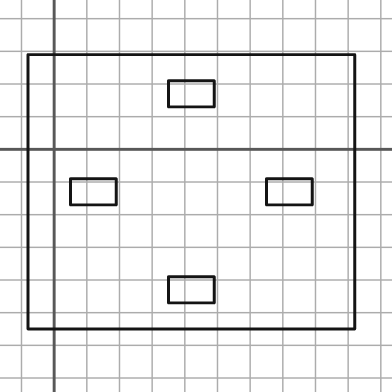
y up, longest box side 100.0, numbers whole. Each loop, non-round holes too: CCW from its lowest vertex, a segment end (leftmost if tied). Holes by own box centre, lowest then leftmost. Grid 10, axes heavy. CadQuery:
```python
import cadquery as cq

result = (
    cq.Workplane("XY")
    .moveTo(-8.0, -55.0)
    .lineTo(92.0, -55.0)
    .lineTo(92.0, 29.0)
    .lineTo(-8.0, 29.0)
    .close()
    .moveTo(35.0, -47.0)
    .lineTo(49.0, -47.0)
    .lineTo(49.0, -39.0)
    .lineTo(35.0, -39.0)
    .close()
    .moveTo(5.0, -17.0)
    .lineTo(19.0, -17.0)
    .lineTo(19.0, -9.0)
    .lineTo(5.0, -9.0)
    .close()
    .moveTo(65.0, -17.0)
    .lineTo(79.0, -17.0)
    .lineTo(79.0, -9.0)
    .lineTo(65.0, -9.0)
    .close()
    .moveTo(35.0, 13.0)
    .lineTo(49.0, 13.0)
    .lineTo(49.0, 21.0)
    .lineTo(35.0, 21.0)
    .close()
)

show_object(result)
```